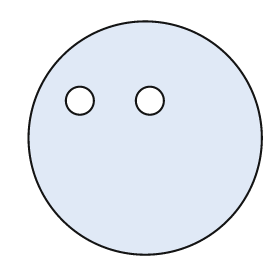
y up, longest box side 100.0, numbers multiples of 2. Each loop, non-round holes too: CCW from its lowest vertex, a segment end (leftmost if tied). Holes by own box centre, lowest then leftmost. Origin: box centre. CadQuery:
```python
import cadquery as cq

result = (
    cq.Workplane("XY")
    .moveTo(0.0, 0.0)
    .circle(50.0)
    .moveTo(-28.0, 16.0)
    .circle(6.0)
    .moveTo(2.0, 16.0)
    .circle(6.0)
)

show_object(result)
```